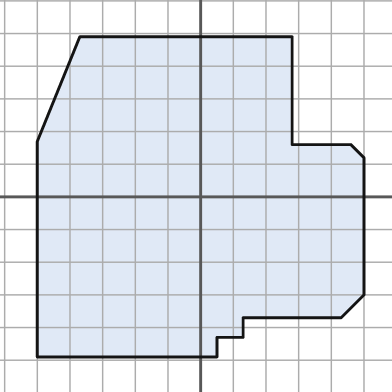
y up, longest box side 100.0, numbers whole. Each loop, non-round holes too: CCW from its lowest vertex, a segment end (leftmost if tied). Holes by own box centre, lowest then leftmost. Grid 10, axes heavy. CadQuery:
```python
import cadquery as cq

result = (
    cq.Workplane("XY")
    .moveTo(-50.0, -49.0)
    .lineTo(5.0, -49.0)
    .lineTo(5.0, -43.0)
    .lineTo(13.0, -43.0)
    .lineTo(13.0, -37.0)
    .lineTo(43.0, -37.0)
    .lineTo(50.0, -30.0)
    .lineTo(50.0, 12.0)
    .lineTo(46.0, 16.0)
    .lineTo(28.0, 16.0)
    .lineTo(28.0, 49.0)
    .lineTo(-37.0, 49.0)
    .lineTo(-50.0, 17.0)
    .close()
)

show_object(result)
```